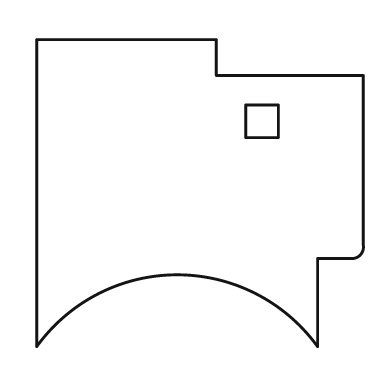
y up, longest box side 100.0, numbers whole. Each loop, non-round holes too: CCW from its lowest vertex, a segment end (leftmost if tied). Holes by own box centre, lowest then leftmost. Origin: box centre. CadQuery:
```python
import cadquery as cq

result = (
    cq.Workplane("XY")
    .moveTo(-50.0, -47.0)
    .threePointArc((-7.0, -25.0), (36.0, -47.0))
    .lineTo(36.0, -20.0)
    .lineTo(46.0, -20.0)
    .threePointArc((49.0, -19.0), (50.0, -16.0))
    .lineTo(50.0, 36.0)
    .lineTo(5.0, 36.0)
    .lineTo(5.0, 47.0)
    .lineTo(-50.0, 47.0)
    .close()
    .moveTo(14.0, 17.0)
    .lineTo(24.0, 17.0)
    .lineTo(24.0, 27.0)
    .lineTo(14.0, 27.0)
    .close()
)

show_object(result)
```